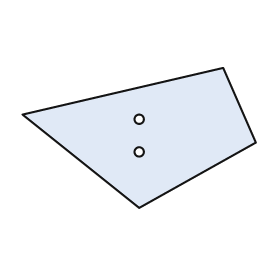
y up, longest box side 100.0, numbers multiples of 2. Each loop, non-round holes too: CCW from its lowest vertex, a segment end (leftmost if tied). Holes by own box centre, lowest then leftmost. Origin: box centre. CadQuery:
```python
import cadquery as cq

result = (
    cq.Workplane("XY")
    .moveTo(0.0, -30.0)
    .lineTo(50.0, -2.0)
    .lineTo(36.0, 30.0)
    .lineTo(-50.0, 10.0)
    .close()
    .moveTo(0.0, -6.0)
    .circle(2.0)
    .moveTo(0.0, 8.0)
    .circle(2.0)
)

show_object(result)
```